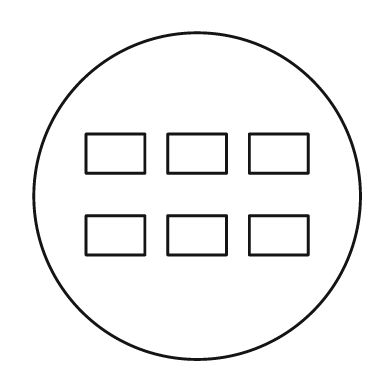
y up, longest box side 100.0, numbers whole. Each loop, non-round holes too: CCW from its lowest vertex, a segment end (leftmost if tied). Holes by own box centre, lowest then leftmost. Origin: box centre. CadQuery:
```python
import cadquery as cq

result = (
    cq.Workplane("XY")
    .moveTo(0.0, 0.0)
    .circle(50.0)
    .moveTo(-34.0, -18.0)
    .lineTo(-16.0, -18.0)
    .lineTo(-16.0, -6.0)
    .lineTo(-34.0, -6.0)
    .close()
    .moveTo(-9.0, -18.0)
    .lineTo(9.0, -18.0)
    .lineTo(9.0, -6.0)
    .lineTo(-9.0, -6.0)
    .close()
    .moveTo(16.0, -18.0)
    .lineTo(34.0, -18.0)
    .lineTo(34.0, -6.0)
    .lineTo(16.0, -6.0)
    .close()
    .moveTo(-34.0, 7.0)
    .lineTo(-16.0, 7.0)
    .lineTo(-16.0, 19.0)
    .lineTo(-34.0, 19.0)
    .close()
    .moveTo(-9.0, 7.0)
    .lineTo(9.0, 7.0)
    .lineTo(9.0, 19.0)
    .lineTo(-9.0, 19.0)
    .close()
    .moveTo(16.0, 7.0)
    .lineTo(34.0, 7.0)
    .lineTo(34.0, 19.0)
    .lineTo(16.0, 19.0)
    .close()
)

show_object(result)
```